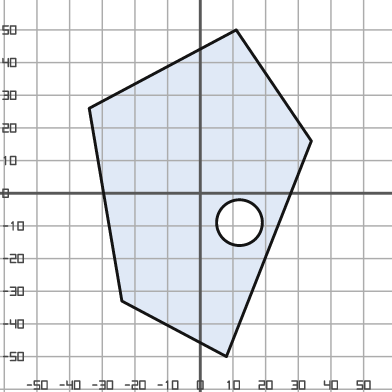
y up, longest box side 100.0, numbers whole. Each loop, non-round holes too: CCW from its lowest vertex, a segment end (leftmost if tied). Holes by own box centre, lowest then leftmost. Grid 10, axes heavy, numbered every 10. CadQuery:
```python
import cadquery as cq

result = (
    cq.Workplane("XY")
    .moveTo(8.0, -50.0)
    .lineTo(34.0, 16.0)
    .lineTo(11.0, 50.0)
    .lineTo(-34.0, 26.0)
    .lineTo(-24.0, -33.0)
    .close()
    .moveTo(12.0, -9.0)
    .circle(7.0)
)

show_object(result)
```